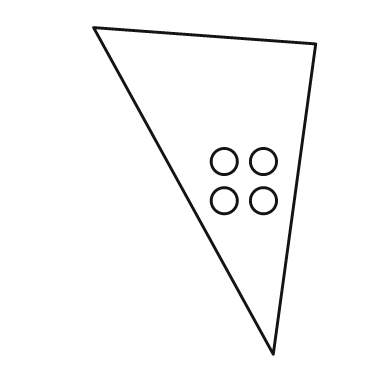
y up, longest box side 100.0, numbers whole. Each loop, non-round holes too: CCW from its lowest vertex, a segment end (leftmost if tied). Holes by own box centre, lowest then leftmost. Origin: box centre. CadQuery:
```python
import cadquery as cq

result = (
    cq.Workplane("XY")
    .moveTo(21.0, -50.0)
    .lineTo(34.0, 45.0)
    .lineTo(-34.0, 50.0)
    .close()
    .moveTo(6.0, -3.0)
    .circle(4.0)
    .moveTo(18.0, -3.0)
    .circle(4.0)
    .moveTo(6.0, 9.0)
    .circle(4.0)
    .moveTo(18.0, 9.0)
    .circle(4.0)
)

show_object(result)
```